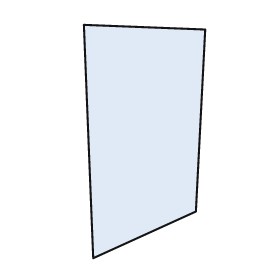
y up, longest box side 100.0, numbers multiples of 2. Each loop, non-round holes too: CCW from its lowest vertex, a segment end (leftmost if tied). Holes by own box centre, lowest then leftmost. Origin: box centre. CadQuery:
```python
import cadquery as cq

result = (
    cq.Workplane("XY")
    .moveTo(-22.0, -50.0)
    .lineTo(22.0, -30.0)
    .lineTo(26.0, 48.0)
    .lineTo(-26.0, 50.0)
    .close()
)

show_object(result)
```